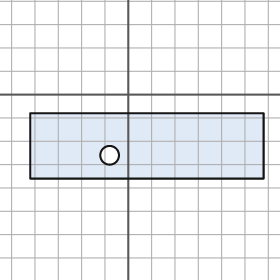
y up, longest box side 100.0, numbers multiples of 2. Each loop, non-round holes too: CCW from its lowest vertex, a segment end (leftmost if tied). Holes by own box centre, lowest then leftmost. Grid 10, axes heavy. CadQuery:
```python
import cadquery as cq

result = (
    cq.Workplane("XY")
    .moveTo(-42.0, -36.0)
    .lineTo(58.0, -36.0)
    .lineTo(58.0, -8.0)
    .lineTo(-42.0, -8.0)
    .close()
    .moveTo(-8.0, -26.0)
    .circle(4.0)
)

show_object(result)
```